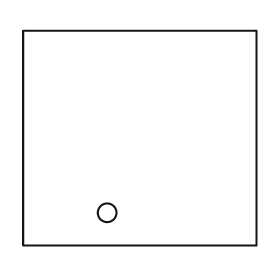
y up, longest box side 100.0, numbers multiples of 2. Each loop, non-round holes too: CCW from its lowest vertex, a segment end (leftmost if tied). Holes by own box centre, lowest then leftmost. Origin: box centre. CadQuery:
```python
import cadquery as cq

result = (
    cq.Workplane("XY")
    .moveTo(-50.0, -46.0)
    .lineTo(50.0, -46.0)
    .lineTo(50.0, 46.0)
    .lineTo(-50.0, 46.0)
    .close()
    .moveTo(-14.0, -32.0)
    .circle(4.0)
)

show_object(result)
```